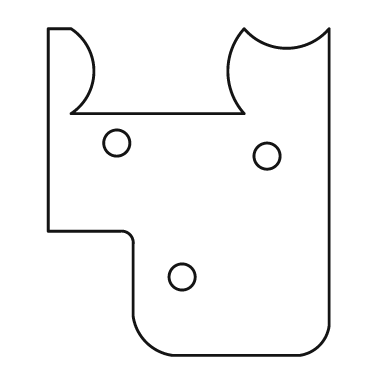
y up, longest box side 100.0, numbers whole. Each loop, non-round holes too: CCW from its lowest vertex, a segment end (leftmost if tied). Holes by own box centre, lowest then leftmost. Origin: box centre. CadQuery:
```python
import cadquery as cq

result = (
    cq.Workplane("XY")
    .moveTo(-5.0, -50.0)
    .lineTo(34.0, -50.0)
    .threePointArc((40.0, -47.0), (43.0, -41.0))
    .lineTo(43.0, 50.0)
    .threePointArc((30.0, 44.0), (17.0, 50.0))
    .threePointArc((12.0, 37.0), (17.0, 24.0))
    .lineTo(-36.0, 24.0)
    .threePointArc((-29.0, 37.0), (-36.0, 50.0))
    .lineTo(-43.0, 50.0)
    .lineTo(-43.0, -12.0)
    .lineTo(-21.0, -12.0)
    .threePointArc((-18.0, -13.0), (-17.0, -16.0))
    .lineTo(-17.0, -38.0)
    .threePointArc((-13.0, -46.0), (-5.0, -50.0))
    .close()
    .moveTo(-2.0, -26.0)
    .circle(4.0)
    .moveTo(24.0, 11.0)
    .circle(4.0)
    .moveTo(-22.0, 15.0)
    .circle(4.0)
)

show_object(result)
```